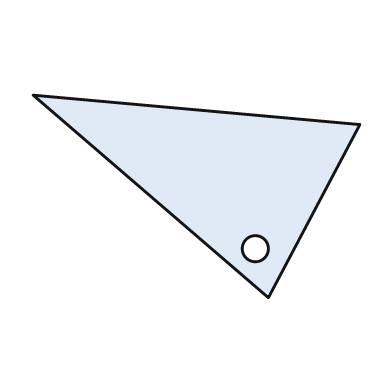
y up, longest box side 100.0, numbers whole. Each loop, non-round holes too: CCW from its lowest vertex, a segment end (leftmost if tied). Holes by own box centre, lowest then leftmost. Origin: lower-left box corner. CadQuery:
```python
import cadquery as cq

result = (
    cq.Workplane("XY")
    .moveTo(72.0, 0.0)
    .lineTo(100.0, 53.0)
    .lineTo(0.0, 62.0)
    .close()
    .moveTo(68.0, 15.0)
    .circle(4.0)
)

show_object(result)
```